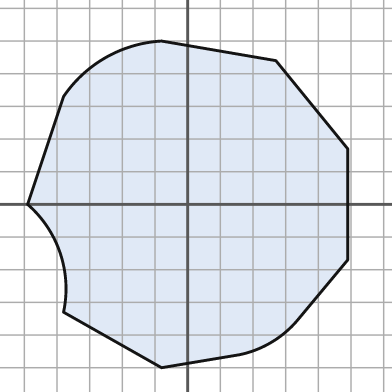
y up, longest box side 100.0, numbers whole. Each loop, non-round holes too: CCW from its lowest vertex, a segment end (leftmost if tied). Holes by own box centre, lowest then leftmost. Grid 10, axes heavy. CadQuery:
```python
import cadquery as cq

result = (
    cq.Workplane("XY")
    .moveTo(-8.0, -50.0)
    .lineTo(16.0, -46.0)
    .threePointArc((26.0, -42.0), (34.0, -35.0))
    .lineTo(49.0, -17.0)
    .lineTo(49.0, 17.0)
    .lineTo(27.0, 44.0)
    .lineTo(-8.0, 50.0)
    .threePointArc((-25.0, 45.0), (-38.0, 33.0))
    .lineTo(-49.0, 0.0)
    .threePointArc((-39.0, -15.0), (-38.0, -33.0))
    .close()
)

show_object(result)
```